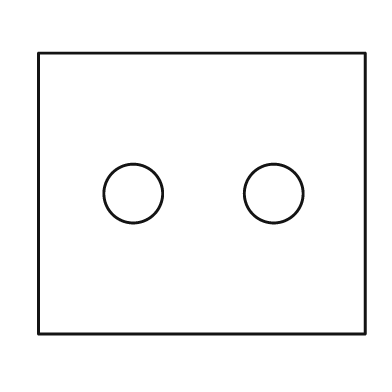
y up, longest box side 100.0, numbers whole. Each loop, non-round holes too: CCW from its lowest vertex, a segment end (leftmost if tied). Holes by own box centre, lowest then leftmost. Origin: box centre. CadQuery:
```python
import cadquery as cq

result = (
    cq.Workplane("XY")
    .moveTo(-50.0, -43.0)
    .lineTo(50.0, -43.0)
    .lineTo(50.0, 43.0)
    .lineTo(-50.0, 43.0)
    .close()
    .moveTo(-21.0, 0.0)
    .circle(9.0)
    .moveTo(22.0, 0.0)
    .circle(9.0)
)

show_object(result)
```